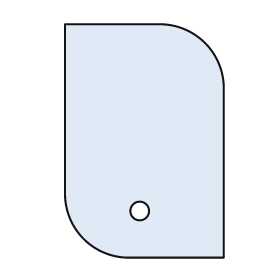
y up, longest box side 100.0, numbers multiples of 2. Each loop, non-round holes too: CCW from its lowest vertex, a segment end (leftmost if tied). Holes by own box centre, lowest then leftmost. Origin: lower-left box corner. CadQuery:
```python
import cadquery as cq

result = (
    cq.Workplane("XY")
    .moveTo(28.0, 0.0)
    .lineTo(68.0, 0.0)
    .lineTo(68.0, 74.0)
    .threePointArc((60.0, 92.0), (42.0, 100.0))
    .lineTo(0.0, 100.0)
    .lineTo(0.0, 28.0)
    .threePointArc((8.0, 8.0), (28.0, 0.0))
    .close()
    .moveTo(32.0, 20.0)
    .circle(4.0)
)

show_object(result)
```